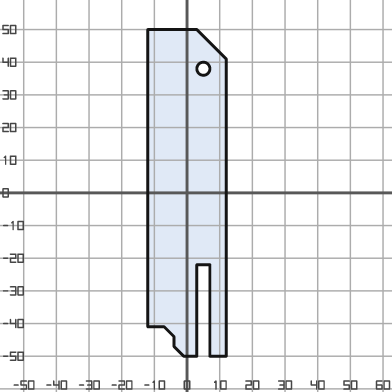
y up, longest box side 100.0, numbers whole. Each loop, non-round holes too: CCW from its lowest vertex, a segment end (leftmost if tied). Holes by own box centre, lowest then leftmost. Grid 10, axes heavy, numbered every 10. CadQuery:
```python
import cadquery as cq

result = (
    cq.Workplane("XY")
    .moveTo(-1.0, -50.0)
    .lineTo(3.0, -50.0)
    .lineTo(3.0, -22.0)
    .lineTo(7.0, -22.0)
    .lineTo(7.0, -50.0)
    .lineTo(12.0, -50.0)
    .lineTo(12.0, 41.0)
    .lineTo(3.0, 50.0)
    .lineTo(-12.0, 50.0)
    .lineTo(-12.0, -41.0)
    .lineTo(-7.0, -41.0)
    .lineTo(-4.0, -44.0)
    .lineTo(-4.0, -47.0)
    .close()
    .moveTo(5.0, 38.0)
    .circle(2.0)
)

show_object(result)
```